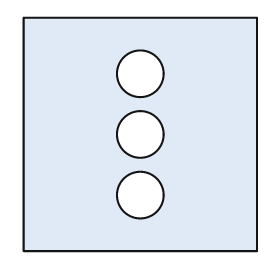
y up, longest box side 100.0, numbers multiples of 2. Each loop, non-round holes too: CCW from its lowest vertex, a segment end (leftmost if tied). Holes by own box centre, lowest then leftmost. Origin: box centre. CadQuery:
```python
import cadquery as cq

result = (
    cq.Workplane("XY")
    .moveTo(-50.0, -50.0)
    .lineTo(50.0, -50.0)
    .lineTo(50.0, 50.0)
    .lineTo(-50.0, 50.0)
    .close()
    .moveTo(0.0, -26.0)
    .circle(10.0)
    .moveTo(0.0, 0.0)
    .circle(10.0)
    .moveTo(0.0, 26.0)
    .circle(10.0)
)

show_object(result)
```